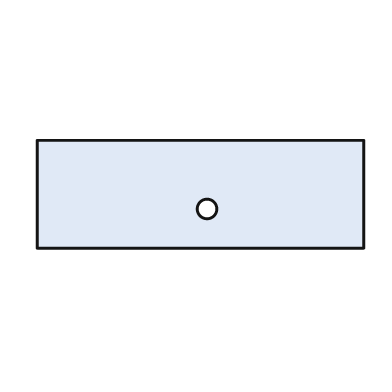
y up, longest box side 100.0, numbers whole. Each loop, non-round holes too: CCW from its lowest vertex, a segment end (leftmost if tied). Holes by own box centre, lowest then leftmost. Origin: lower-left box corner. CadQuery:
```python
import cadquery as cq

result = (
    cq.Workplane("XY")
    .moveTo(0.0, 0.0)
    .lineTo(100.0, 0.0)
    .lineTo(100.0, 33.0)
    .lineTo(0.0, 33.0)
    .close()
    .moveTo(52.0, 12.0)
    .circle(3.0)
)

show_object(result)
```